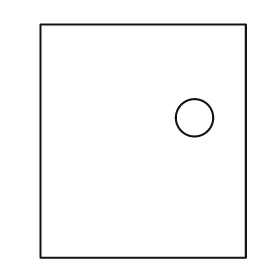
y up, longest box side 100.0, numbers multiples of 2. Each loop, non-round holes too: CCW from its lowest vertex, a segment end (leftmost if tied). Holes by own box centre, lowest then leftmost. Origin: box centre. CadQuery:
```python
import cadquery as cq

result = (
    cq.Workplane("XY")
    .moveTo(-44.0, -50.0)
    .lineTo(44.0, -50.0)
    .lineTo(44.0, 50.0)
    .lineTo(-44.0, 50.0)
    .close()
    .moveTo(22.0, 10.0)
    .circle(8.0)
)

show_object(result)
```